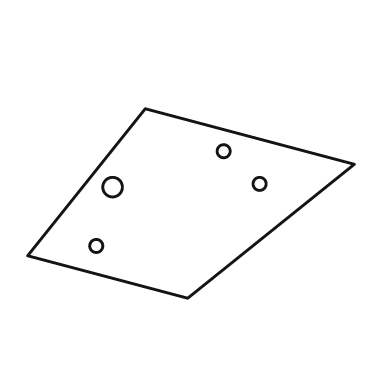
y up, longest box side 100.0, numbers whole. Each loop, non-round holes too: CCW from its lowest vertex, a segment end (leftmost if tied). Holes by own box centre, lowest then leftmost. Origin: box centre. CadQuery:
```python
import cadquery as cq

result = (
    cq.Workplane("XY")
    .moveTo(-1.0, -29.0)
    .lineTo(50.0, 12.0)
    .lineTo(-14.0, 29.0)
    .lineTo(-50.0, -16.0)
    .close()
    .moveTo(-29.0, -13.0)
    .circle(2.0)
    .moveTo(-24.0, 5.0)
    .circle(3.0)
    .moveTo(21.0, 6.0)
    .circle(2.0)
    .moveTo(10.0, 16.0)
    .circle(2.0)
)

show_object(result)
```